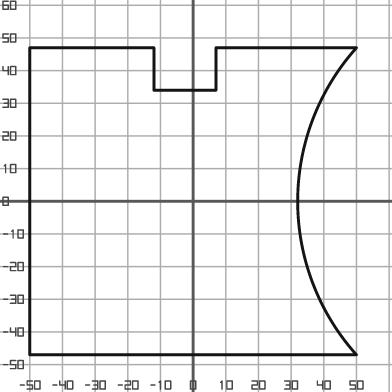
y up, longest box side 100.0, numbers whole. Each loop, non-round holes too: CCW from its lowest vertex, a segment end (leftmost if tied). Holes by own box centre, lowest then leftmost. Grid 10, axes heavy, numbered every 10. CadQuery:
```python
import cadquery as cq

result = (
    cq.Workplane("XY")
    .moveTo(-50.0, -47.0)
    .lineTo(50.0, -47.0)
    .threePointArc((32.0, 0.0), (50.0, 47.0))
    .lineTo(7.0, 47.0)
    .lineTo(7.0, 34.0)
    .lineTo(-12.0, 34.0)
    .lineTo(-12.0, 47.0)
    .lineTo(-50.0, 47.0)
    .close()
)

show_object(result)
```